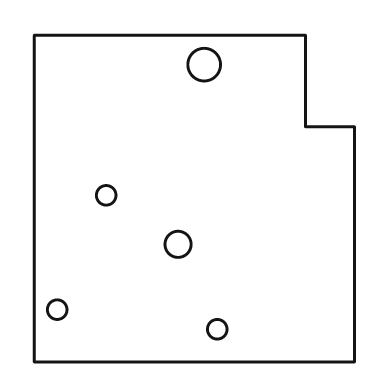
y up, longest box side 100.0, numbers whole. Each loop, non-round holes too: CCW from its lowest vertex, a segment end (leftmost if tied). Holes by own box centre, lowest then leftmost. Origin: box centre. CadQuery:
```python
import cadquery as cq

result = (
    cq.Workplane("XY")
    .moveTo(-49.0, -50.0)
    .lineTo(49.0, -50.0)
    .lineTo(49.0, 22.0)
    .lineTo(34.0, 22.0)
    .lineTo(34.0, 50.0)
    .lineTo(-49.0, 50.0)
    .close()
    .moveTo(7.0, -40.0)
    .circle(3.0)
    .moveTo(-42.0, -34.0)
    .circle(3.0)
    .moveTo(-5.0, -14.0)
    .circle(4.0)
    .moveTo(-27.0, 1.0)
    .circle(3.0)
    .moveTo(3.0, 41.0)
    .circle(5.0)
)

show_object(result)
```